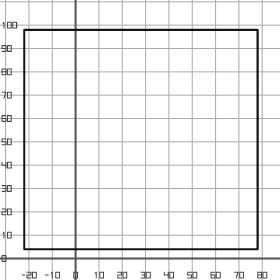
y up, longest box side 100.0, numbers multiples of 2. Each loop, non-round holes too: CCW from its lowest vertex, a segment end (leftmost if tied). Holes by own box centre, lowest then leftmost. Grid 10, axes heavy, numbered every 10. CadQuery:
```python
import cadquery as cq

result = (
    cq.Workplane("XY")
    .moveTo(-22.0, 4.0)
    .lineTo(78.0, 4.0)
    .lineTo(78.0, 98.0)
    .lineTo(-22.0, 98.0)
    .close()
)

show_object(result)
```